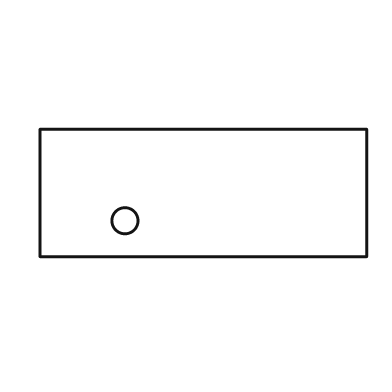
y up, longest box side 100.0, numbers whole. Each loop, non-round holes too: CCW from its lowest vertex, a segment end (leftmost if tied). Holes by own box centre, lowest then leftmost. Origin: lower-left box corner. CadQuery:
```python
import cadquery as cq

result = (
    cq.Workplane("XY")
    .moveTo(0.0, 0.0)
    .lineTo(100.0, 0.0)
    .lineTo(100.0, 39.0)
    .lineTo(0.0, 39.0)
    .close()
    .moveTo(26.0, 11.0)
    .circle(4.0)
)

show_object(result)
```